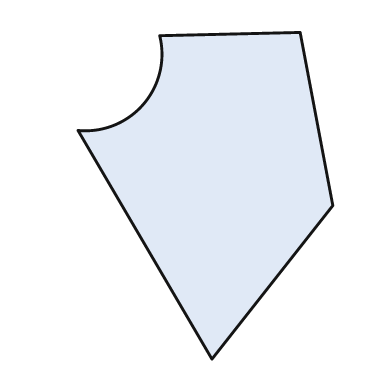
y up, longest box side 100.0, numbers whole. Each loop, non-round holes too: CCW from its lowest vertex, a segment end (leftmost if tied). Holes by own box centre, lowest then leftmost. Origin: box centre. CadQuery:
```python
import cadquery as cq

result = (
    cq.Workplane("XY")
    .moveTo(2.0, -50.0)
    .lineTo(39.0, -3.0)
    .lineTo(29.0, 50.0)
    .lineTo(-14.0, 49.0)
    .threePointArc((-19.0, 28.0), (-39.0, 20.0))
    .close()
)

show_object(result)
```